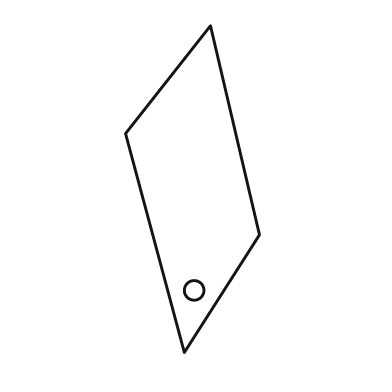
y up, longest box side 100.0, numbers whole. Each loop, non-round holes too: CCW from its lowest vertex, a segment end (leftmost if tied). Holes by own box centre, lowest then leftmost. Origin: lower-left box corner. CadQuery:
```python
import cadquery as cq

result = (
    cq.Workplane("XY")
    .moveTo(18.0, 0.0)
    .lineTo(41.0, 36.0)
    .lineTo(26.0, 100.0)
    .lineTo(0.0, 67.0)
    .close()
    .moveTo(21.0, 19.0)
    .circle(3.0)
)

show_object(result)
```